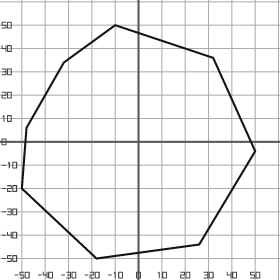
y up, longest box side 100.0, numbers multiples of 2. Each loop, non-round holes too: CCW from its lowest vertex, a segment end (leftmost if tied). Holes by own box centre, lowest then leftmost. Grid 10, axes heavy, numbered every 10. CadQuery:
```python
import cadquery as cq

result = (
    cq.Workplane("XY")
    .moveTo(-18.0, -50.0)
    .lineTo(26.0, -44.0)
    .lineTo(50.0, -4.0)
    .lineTo(32.0, 36.0)
    .lineTo(-10.0, 50.0)
    .lineTo(-32.0, 34.0)
    .lineTo(-48.0, 6.0)
    .lineTo(-50.0, -20.0)
    .close()
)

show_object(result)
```